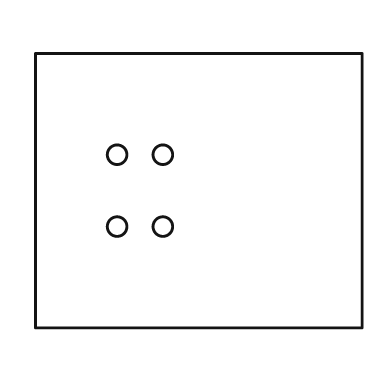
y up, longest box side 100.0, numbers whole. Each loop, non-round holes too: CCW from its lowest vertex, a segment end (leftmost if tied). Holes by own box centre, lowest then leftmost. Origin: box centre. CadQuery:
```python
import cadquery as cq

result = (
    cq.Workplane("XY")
    .moveTo(-50.0, -42.0)
    .lineTo(50.0, -42.0)
    .lineTo(50.0, 42.0)
    .lineTo(-50.0, 42.0)
    .close()
    .moveTo(-25.0, -11.0)
    .circle(3.0)
    .moveTo(-11.0, -11.0)
    .circle(3.0)
    .moveTo(-25.0, 11.0)
    .circle(3.0)
    .moveTo(-11.0, 11.0)
    .circle(3.0)
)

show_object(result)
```